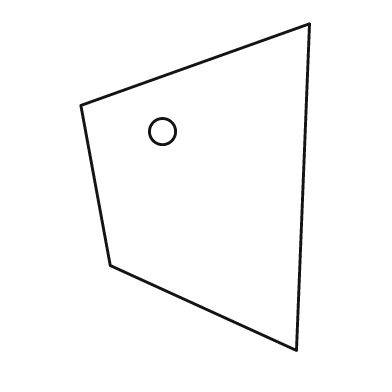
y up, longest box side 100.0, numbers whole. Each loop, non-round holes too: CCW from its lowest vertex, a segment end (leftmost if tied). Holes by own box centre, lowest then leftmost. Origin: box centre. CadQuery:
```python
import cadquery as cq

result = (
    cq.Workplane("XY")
    .moveTo(31.0, -50.0)
    .lineTo(35.0, 50.0)
    .lineTo(-35.0, 25.0)
    .lineTo(-26.0, -24.0)
    .close()
    .moveTo(-10.0, 17.0)
    .circle(4.0)
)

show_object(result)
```